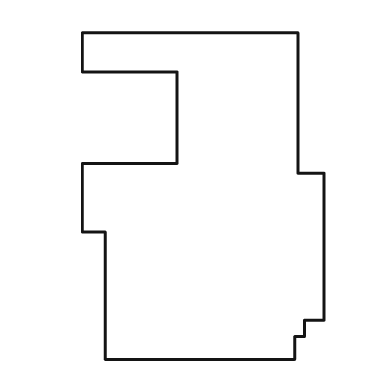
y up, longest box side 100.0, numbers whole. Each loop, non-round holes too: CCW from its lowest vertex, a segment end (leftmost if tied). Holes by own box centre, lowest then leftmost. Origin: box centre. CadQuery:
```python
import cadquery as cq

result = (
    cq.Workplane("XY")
    .moveTo(-30.0, -50.0)
    .lineTo(28.0, -50.0)
    .lineTo(28.0, -43.0)
    .lineTo(31.0, -43.0)
    .lineTo(31.0, -38.0)
    .lineTo(37.0, -38.0)
    .lineTo(37.0, 7.0)
    .lineTo(29.0, 7.0)
    .lineTo(29.0, 50.0)
    .lineTo(-37.0, 50.0)
    .lineTo(-37.0, 38.0)
    .lineTo(-8.0, 38.0)
    .lineTo(-8.0, 10.0)
    .lineTo(-37.0, 10.0)
    .lineTo(-37.0, -11.0)
    .lineTo(-30.0, -11.0)
    .close()
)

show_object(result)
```